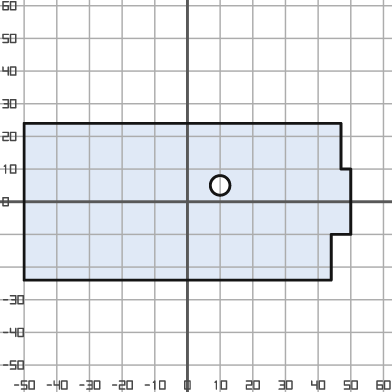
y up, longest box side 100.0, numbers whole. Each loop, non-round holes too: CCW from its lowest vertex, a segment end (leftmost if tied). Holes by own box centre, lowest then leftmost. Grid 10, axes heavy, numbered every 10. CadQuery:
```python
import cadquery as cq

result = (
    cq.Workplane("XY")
    .moveTo(-50.0, -24.0)
    .lineTo(44.0, -24.0)
    .lineTo(44.0, -10.0)
    .lineTo(50.0, -10.0)
    .lineTo(50.0, 10.0)
    .lineTo(47.0, 10.0)
    .lineTo(47.0, 24.0)
    .lineTo(-50.0, 24.0)
    .close()
    .moveTo(10.0, 5.0)
    .circle(3.0)
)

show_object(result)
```